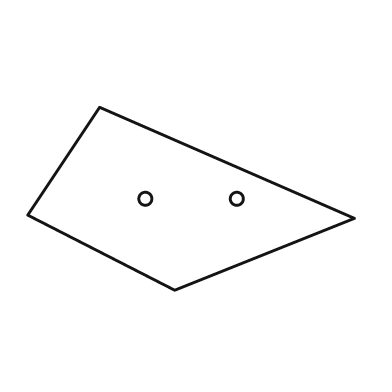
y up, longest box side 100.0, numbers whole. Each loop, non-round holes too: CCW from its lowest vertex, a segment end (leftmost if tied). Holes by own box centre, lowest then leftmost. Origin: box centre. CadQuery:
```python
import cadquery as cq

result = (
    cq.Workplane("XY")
    .moveTo(-5.0, -28.0)
    .lineTo(50.0, -6.0)
    .lineTo(-28.0, 28.0)
    .lineTo(-50.0, -5.0)
    .close()
    .moveTo(-14.0, 0.0)
    .circle(2.0)
    .moveTo(14.0, 0.0)
    .circle(2.0)
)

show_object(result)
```